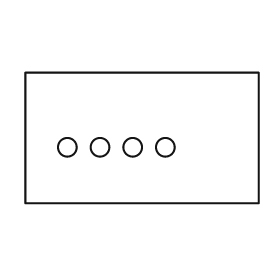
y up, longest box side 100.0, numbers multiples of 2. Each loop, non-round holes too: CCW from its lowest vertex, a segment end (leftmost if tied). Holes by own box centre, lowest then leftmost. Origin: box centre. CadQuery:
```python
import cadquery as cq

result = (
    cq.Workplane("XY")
    .moveTo(-50.0, -28.0)
    .lineTo(50.0, -28.0)
    .lineTo(50.0, 28.0)
    .lineTo(-50.0, 28.0)
    .close()
    .moveTo(-32.0, -4.0)
    .circle(4.0)
    .moveTo(-18.0, -4.0)
    .circle(4.0)
    .moveTo(-4.0, -4.0)
    .circle(4.0)
    .moveTo(10.0, -4.0)
    .circle(4.0)
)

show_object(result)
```